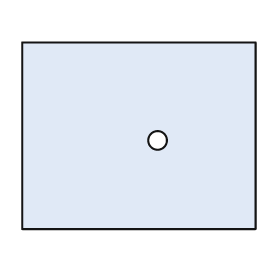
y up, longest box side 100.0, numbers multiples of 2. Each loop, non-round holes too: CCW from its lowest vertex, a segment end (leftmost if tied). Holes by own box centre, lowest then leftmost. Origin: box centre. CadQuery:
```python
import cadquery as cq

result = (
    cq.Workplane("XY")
    .moveTo(-50.0, -40.0)
    .lineTo(50.0, -40.0)
    .lineTo(50.0, 40.0)
    .lineTo(-50.0, 40.0)
    .close()
    .moveTo(8.0, -2.0)
    .circle(4.0)
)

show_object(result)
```